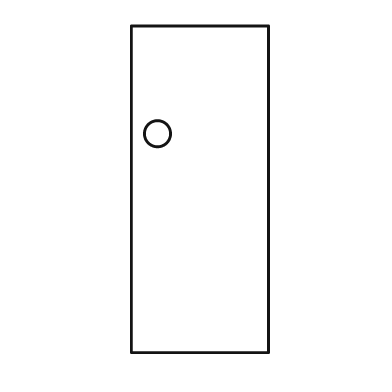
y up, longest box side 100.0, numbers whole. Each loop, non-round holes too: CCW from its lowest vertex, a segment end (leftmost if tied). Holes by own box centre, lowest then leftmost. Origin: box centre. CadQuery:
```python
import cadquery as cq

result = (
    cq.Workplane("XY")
    .moveTo(-21.0, -50.0)
    .lineTo(21.0, -50.0)
    .lineTo(21.0, 50.0)
    .lineTo(-21.0, 50.0)
    .close()
    .moveTo(-13.0, 17.0)
    .circle(4.0)
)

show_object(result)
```